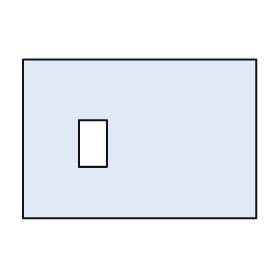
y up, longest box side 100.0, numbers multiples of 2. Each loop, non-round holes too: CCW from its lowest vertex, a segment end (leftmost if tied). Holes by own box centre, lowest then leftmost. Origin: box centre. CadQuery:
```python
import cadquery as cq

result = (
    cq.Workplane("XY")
    .moveTo(-50.0, -34.0)
    .lineTo(50.0, -34.0)
    .lineTo(50.0, 34.0)
    .lineTo(-50.0, 34.0)
    .close()
    .moveTo(-26.0, -12.0)
    .lineTo(-14.0, -12.0)
    .lineTo(-14.0, 8.0)
    .lineTo(-26.0, 8.0)
    .close()
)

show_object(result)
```